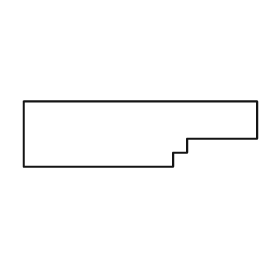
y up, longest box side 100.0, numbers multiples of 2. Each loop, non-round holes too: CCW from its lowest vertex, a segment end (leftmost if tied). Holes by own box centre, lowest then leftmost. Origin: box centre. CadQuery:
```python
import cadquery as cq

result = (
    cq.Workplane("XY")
    .moveTo(-50.0, -14.0)
    .lineTo(14.0, -14.0)
    .lineTo(14.0, -8.0)
    .lineTo(20.0, -8.0)
    .lineTo(20.0, -2.0)
    .lineTo(50.0, -2.0)
    .lineTo(50.0, 14.0)
    .lineTo(-50.0, 14.0)
    .close()
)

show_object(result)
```